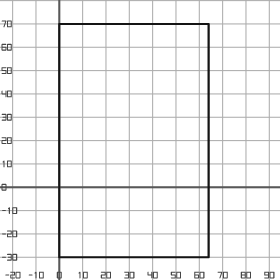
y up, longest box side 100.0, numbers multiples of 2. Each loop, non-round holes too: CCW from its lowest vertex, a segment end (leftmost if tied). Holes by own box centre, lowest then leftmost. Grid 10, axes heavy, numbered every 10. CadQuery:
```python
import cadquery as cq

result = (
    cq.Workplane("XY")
    .moveTo(0.0, -30.0)
    .lineTo(64.0, -30.0)
    .lineTo(64.0, 70.0)
    .lineTo(0.0, 70.0)
    .close()
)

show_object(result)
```